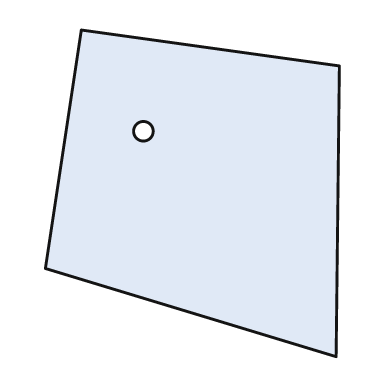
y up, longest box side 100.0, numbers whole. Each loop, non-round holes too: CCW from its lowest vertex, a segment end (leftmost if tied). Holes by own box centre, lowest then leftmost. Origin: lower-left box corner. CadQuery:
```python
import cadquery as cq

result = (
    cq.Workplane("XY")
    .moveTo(89.0, 0.0)
    .lineTo(90.0, 89.0)
    .lineTo(11.0, 100.0)
    .lineTo(0.0, 27.0)
    .close()
    .moveTo(30.0, 69.0)
    .circle(3.0)
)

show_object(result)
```